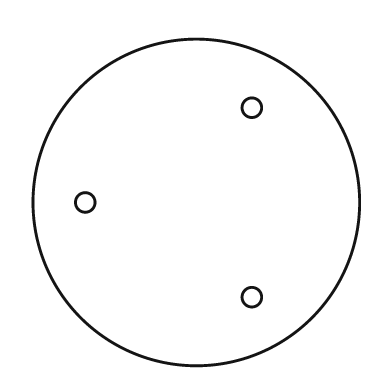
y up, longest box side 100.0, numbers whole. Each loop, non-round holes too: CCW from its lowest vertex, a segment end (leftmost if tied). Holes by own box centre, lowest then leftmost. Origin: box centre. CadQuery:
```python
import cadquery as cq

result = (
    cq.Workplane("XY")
    .moveTo(0.0, 0.0)
    .circle(50.0)
    .moveTo(17.0, -29.0)
    .circle(3.0)
    .moveTo(-34.0, 0.0)
    .circle(3.0)
    .moveTo(17.0, 29.0)
    .circle(3.0)
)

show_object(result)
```